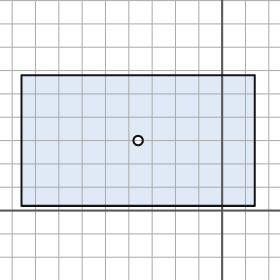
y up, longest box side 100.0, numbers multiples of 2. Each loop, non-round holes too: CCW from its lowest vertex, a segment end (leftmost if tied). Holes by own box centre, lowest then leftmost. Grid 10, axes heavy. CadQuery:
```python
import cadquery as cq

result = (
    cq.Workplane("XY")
    .moveTo(-86.0, 2.0)
    .lineTo(14.0, 2.0)
    .lineTo(14.0, 58.0)
    .lineTo(-86.0, 58.0)
    .close()
    .moveTo(-36.0, 30.0)
    .circle(2.0)
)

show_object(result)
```